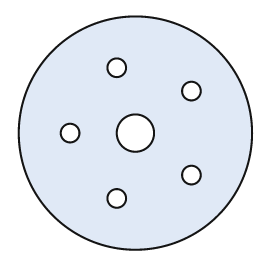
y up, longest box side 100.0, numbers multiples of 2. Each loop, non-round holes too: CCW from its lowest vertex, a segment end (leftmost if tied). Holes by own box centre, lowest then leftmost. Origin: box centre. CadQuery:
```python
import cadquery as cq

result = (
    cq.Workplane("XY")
    .moveTo(0.0, 0.0)
    .circle(50.0)
    .moveTo(-8.0, -28.0)
    .circle(4.0)
    .moveTo(24.0, -18.0)
    .circle(4.0)
    .moveTo(-28.0, 0.0)
    .circle(4.0)
    .moveTo(0.0, 0.0)
    .circle(8.0)
    .moveTo(24.0, 18.0)
    .circle(4.0)
    .moveTo(-8.0, 28.0)
    .circle(4.0)
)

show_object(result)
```